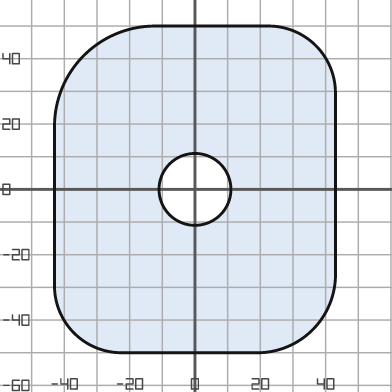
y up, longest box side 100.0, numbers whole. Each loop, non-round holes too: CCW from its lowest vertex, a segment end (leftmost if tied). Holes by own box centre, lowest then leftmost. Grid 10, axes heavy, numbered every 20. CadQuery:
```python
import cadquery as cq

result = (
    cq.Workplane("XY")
    .moveTo(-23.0, -50.0)
    .lineTo(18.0, -50.0)
    .threePointArc((36.0, -43.0), (43.0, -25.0))
    .lineTo(43.0, 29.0)
    .threePointArc((37.0, 44.0), (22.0, 50.0))
    .lineTo(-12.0, 50.0)
    .threePointArc((-34.0, 41.0), (-43.0, 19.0))
    .lineTo(-43.0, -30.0)
    .threePointArc((-37.0, -44.0), (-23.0, -50.0))
    .close()
    .moveTo(0.0, 0.0)
    .circle(11.0)
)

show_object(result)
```